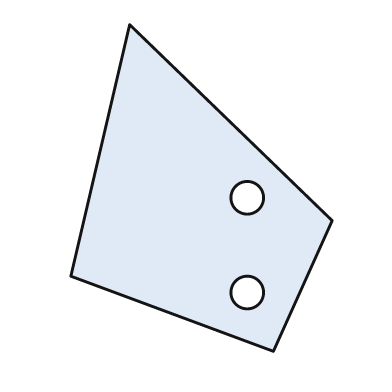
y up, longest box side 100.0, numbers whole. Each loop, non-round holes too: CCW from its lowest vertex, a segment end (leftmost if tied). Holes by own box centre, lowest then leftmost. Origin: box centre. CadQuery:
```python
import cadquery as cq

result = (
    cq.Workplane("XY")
    .moveTo(22.0, -50.0)
    .lineTo(40.0, -10.0)
    .lineTo(-22.0, 50.0)
    .lineTo(-40.0, -27.0)
    .close()
    .moveTo(14.0, -32.0)
    .circle(5.0)
    .moveTo(14.0, -3.0)
    .circle(5.0)
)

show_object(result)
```